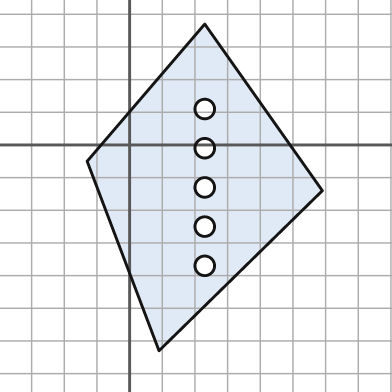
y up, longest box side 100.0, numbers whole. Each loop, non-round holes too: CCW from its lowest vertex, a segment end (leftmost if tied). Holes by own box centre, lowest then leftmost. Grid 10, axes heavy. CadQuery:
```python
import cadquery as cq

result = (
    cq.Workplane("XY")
    .moveTo(9.0, -63.0)
    .lineTo(59.0, -14.0)
    .lineTo(23.0, 37.0)
    .lineTo(-13.0, -5.0)
    .close()
    .moveTo(23.0, -37.0)
    .circle(3.0)
    .moveTo(23.0, -25.0)
    .circle(3.0)
    .moveTo(23.0, -13.0)
    .circle(3.0)
    .moveTo(23.0, -1.0)
    .circle(3.0)
    .moveTo(23.0, 11.0)
    .circle(3.0)
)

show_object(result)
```